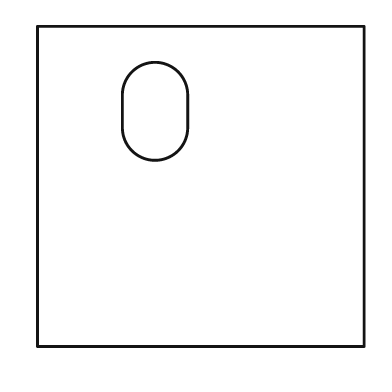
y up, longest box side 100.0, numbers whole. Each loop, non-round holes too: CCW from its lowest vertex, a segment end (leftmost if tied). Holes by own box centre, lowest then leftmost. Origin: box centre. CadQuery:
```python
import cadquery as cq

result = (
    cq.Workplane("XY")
    .moveTo(-50.0, -49.0)
    .lineTo(50.0, -49.0)
    .lineTo(50.0, 49.0)
    .lineTo(-50.0, 49.0)
    .close()
    .moveTo(-24.0, 18.0)
    .threePointArc((-14.0, 8.0), (-4.0, 18.0))
    .lineTo(-4.0, 28.0)
    .threePointArc((-14.0, 38.0), (-24.0, 28.0))
    .close()
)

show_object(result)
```